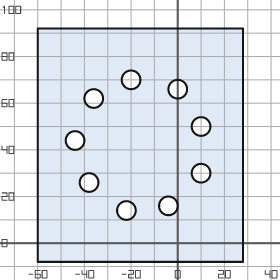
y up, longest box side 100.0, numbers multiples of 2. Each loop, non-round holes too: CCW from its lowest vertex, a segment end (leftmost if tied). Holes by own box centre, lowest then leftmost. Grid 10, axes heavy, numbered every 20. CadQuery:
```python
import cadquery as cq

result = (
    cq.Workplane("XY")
    .moveTo(-60.0, -8.0)
    .lineTo(28.0, -8.0)
    .lineTo(28.0, 92.0)
    .lineTo(-60.0, 92.0)
    .close()
    .moveTo(-22.0, 14.0)
    .circle(4.0)
    .moveTo(-4.0, 16.0)
    .circle(4.0)
    .moveTo(-38.0, 26.0)
    .circle(4.0)
    .moveTo(10.0, 30.0)
    .circle(4.0)
    .moveTo(-44.0, 44.0)
    .circle(4.0)
    .moveTo(10.0, 50.0)
    .circle(4.0)
    .moveTo(-36.0, 62.0)
    .circle(4.0)
    .moveTo(0.0, 66.0)
    .circle(4.0)
    .moveTo(-20.0, 70.0)
    .circle(4.0)
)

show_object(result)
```